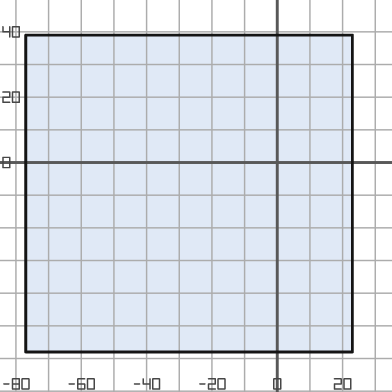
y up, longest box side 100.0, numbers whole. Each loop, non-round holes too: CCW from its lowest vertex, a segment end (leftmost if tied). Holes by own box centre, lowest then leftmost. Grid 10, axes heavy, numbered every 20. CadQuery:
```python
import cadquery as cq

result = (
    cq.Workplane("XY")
    .moveTo(-77.0, -58.0)
    .lineTo(23.0, -58.0)
    .lineTo(23.0, 39.0)
    .lineTo(-77.0, 39.0)
    .close()
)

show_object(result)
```